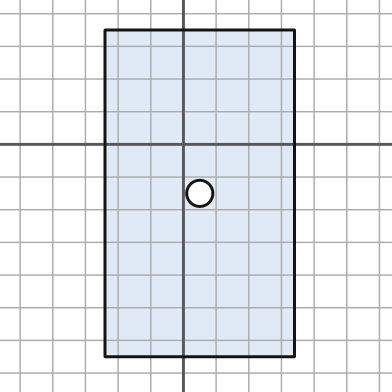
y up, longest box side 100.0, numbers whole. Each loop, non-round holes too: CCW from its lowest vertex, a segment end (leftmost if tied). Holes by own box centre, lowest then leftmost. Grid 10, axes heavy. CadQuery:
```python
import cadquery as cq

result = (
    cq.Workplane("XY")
    .moveTo(-24.0, -65.0)
    .lineTo(34.0, -65.0)
    .lineTo(34.0, 35.0)
    .lineTo(-24.0, 35.0)
    .close()
    .moveTo(5.0, -15.0)
    .circle(4.0)
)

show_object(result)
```